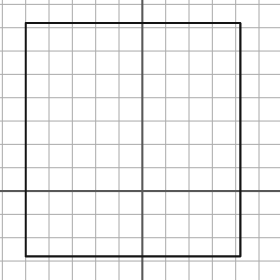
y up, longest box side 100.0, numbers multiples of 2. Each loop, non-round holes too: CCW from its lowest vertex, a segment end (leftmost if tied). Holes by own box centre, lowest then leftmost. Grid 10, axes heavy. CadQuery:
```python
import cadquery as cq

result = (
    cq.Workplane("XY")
    .moveTo(-50.0, -28.0)
    .lineTo(42.0, -28.0)
    .lineTo(42.0, 72.0)
    .lineTo(-50.0, 72.0)
    .close()
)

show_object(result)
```